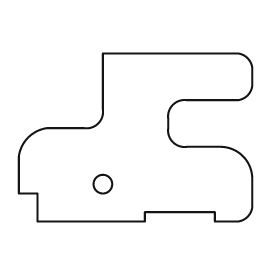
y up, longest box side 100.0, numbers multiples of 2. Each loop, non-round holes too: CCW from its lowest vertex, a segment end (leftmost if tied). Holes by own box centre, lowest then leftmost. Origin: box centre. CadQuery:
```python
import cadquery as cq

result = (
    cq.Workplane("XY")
    .moveTo(-42.0, -36.0)
    .lineTo(4.0, -36.0)
    .lineTo(4.0, -32.0)
    .lineTo(34.0, -32.0)
    .lineTo(34.0, -36.0)
    .lineTo(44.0, -36.0)
    .threePointArc((48.0, -34.0), (50.0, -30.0))
    .lineTo(50.0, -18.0)
    .threePointArc((46.0, -8.0), (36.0, -4.0))
    .lineTo(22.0, -4.0)
    .threePointArc((16.0, -2.0), (14.0, 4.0))
    .lineTo(14.0, 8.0)
    .threePointArc((16.0, 14.0), (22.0, 16.0))
    .lineTo(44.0, 16.0)
    .threePointArc((48.0, 18.0), (50.0, 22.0))
    .lineTo(50.0, 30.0)
    .threePointArc((48.0, 34.0), (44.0, 36.0))
    .lineTo(-14.0, 36.0)
    .lineTo(-14.0, 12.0)
    .threePointArc((-16.0, 6.0), (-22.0, 4.0))
    .lineTo(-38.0, 4.0)
    .threePointArc((-46.0, 0.0), (-50.0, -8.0))
    .lineTo(-50.0, -24.0)
    .lineTo(-42.0, -24.0)
    .close()
    .moveTo(-14.0, -20.0)
    .circle(4.0)
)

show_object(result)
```